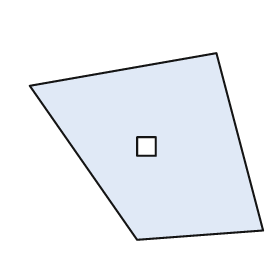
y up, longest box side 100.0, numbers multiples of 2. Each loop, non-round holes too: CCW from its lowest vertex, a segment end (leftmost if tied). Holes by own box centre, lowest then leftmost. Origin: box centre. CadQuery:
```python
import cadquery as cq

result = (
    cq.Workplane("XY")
    .moveTo(-4.0, -40.0)
    .lineTo(50.0, -36.0)
    .lineTo(30.0, 40.0)
    .lineTo(-50.0, 26.0)
    .close()
    .moveTo(-4.0, -4.0)
    .lineTo(4.0, -4.0)
    .lineTo(4.0, 4.0)
    .lineTo(-4.0, 4.0)
    .close()
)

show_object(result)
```